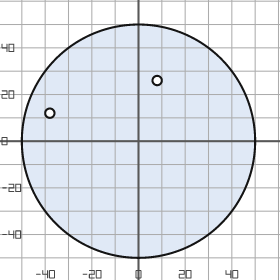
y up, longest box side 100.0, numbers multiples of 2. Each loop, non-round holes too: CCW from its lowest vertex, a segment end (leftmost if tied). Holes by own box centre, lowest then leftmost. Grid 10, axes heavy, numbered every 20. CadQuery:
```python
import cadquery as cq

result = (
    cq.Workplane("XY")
    .moveTo(0.0, 0.0)
    .circle(50.0)
    .moveTo(-38.0, 12.0)
    .circle(2.0)
    .moveTo(8.0, 26.0)
    .circle(2.0)
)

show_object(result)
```